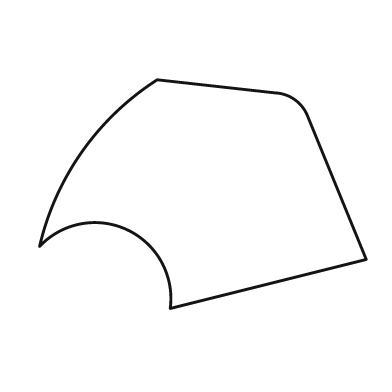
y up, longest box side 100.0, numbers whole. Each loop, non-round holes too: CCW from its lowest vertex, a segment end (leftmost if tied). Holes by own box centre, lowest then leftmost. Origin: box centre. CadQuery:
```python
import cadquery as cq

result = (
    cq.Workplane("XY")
    .moveTo(-10.0, -35.0)
    .lineTo(50.0, -20.0)
    .lineTo(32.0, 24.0)
    .threePointArc((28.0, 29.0), (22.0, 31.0))
    .lineTo(-14.0, 35.0)
    .threePointArc((-37.0, 13.0), (-50.0, -16.0))
    .threePointArc((-23.0, -11.0), (-10.0, -35.0))
    .close()
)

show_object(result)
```